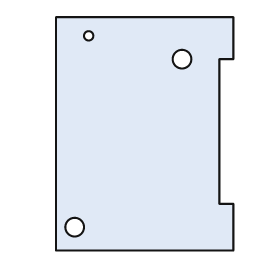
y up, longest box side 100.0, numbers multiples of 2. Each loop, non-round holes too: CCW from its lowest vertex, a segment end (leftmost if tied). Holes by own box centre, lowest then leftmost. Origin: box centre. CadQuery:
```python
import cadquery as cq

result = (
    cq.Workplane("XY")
    .moveTo(-38.0, -50.0)
    .lineTo(38.0, -50.0)
    .lineTo(38.0, -30.0)
    .lineTo(32.0, -30.0)
    .lineTo(32.0, 32.0)
    .lineTo(38.0, 32.0)
    .lineTo(38.0, 50.0)
    .lineTo(-38.0, 50.0)
    .close()
    .moveTo(-30.0, -40.0)
    .circle(4.0)
    .moveTo(16.0, 32.0)
    .circle(4.0)
    .moveTo(-24.0, 42.0)
    .circle(2.0)
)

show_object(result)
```